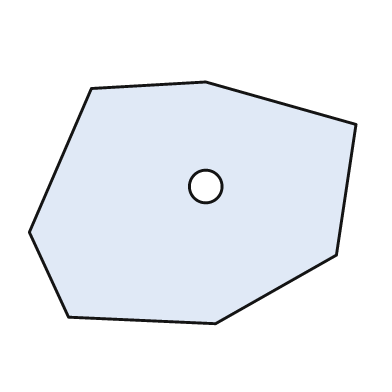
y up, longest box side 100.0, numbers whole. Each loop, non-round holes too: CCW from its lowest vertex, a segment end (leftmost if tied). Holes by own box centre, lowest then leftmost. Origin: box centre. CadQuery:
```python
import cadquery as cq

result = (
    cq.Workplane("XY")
    .moveTo(7.0, -37.0)
    .lineTo(44.0, -16.0)
    .lineTo(50.0, 24.0)
    .lineTo(4.0, 37.0)
    .lineTo(-31.0, 35.0)
    .lineTo(-50.0, -9.0)
    .lineTo(-38.0, -35.0)
    .close()
    .moveTo(4.0, 5.0)
    .circle(5.0)
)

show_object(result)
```